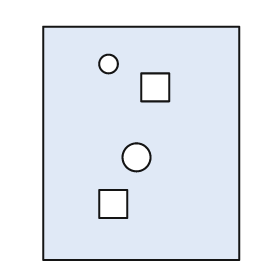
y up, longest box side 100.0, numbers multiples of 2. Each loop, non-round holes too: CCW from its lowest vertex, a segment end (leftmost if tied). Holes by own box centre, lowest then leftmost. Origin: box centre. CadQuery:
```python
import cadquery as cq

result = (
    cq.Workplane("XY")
    .moveTo(-42.0, -50.0)
    .lineTo(42.0, -50.0)
    .lineTo(42.0, 50.0)
    .lineTo(-42.0, 50.0)
    .close()
    .moveTo(-18.0, -32.0)
    .lineTo(-6.0, -32.0)
    .lineTo(-6.0, -20.0)
    .lineTo(-18.0, -20.0)
    .close()
    .moveTo(-2.0, -6.0)
    .circle(6.0)
    .moveTo(0.0, 18.0)
    .lineTo(12.0, 18.0)
    .lineTo(12.0, 30.0)
    .lineTo(0.0, 30.0)
    .close()
    .moveTo(-14.0, 34.0)
    .circle(4.0)
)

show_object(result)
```